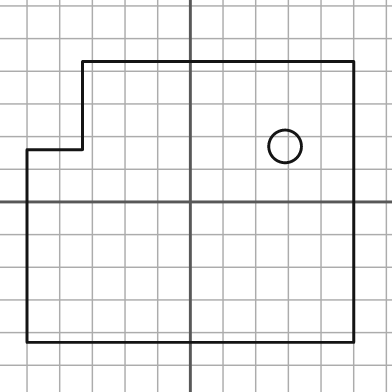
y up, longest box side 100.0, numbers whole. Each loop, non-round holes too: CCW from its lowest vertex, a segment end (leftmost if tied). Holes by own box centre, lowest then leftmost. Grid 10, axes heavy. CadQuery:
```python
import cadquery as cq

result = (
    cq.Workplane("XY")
    .moveTo(-50.0, -43.0)
    .lineTo(50.0, -43.0)
    .lineTo(50.0, 43.0)
    .lineTo(-33.0, 43.0)
    .lineTo(-33.0, 16.0)
    .lineTo(-50.0, 16.0)
    .close()
    .moveTo(29.0, 17.0)
    .circle(5.0)
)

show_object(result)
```